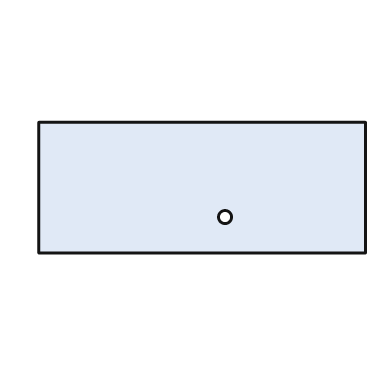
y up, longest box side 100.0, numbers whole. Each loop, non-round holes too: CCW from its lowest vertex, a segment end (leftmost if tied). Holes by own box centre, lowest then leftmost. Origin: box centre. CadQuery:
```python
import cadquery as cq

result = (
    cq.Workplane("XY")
    .moveTo(-50.0, -20.0)
    .lineTo(50.0, -20.0)
    .lineTo(50.0, 20.0)
    .lineTo(-50.0, 20.0)
    .close()
    .moveTo(7.0, -9.0)
    .circle(2.0)
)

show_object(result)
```